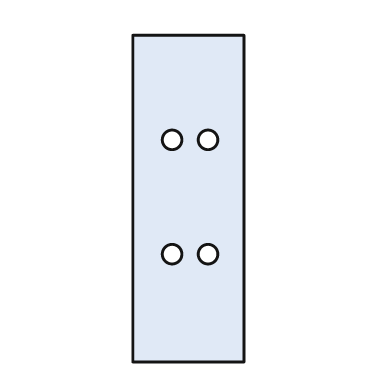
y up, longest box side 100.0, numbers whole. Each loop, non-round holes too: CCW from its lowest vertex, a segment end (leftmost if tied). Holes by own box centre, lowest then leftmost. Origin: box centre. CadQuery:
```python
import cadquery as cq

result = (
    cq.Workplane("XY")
    .moveTo(-17.0, -50.0)
    .lineTo(17.0, -50.0)
    .lineTo(17.0, 50.0)
    .lineTo(-17.0, 50.0)
    .close()
    .moveTo(-5.0, -17.0)
    .circle(3.0)
    .moveTo(6.0, -17.0)
    .circle(3.0)
    .moveTo(-5.0, 18.0)
    .circle(3.0)
    .moveTo(6.0, 18.0)
    .circle(3.0)
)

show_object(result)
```